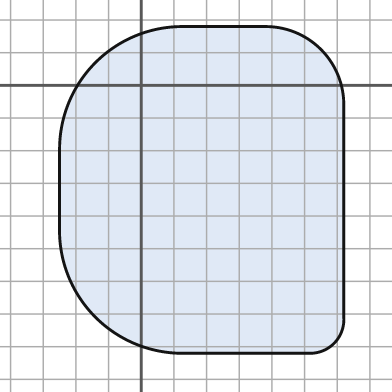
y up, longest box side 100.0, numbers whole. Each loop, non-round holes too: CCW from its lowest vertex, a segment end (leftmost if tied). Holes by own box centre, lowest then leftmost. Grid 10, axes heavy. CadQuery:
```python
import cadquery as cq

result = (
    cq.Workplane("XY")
    .moveTo(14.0, -82.0)
    .lineTo(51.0, -82.0)
    .threePointArc((59.0, -79.0), (62.0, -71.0))
    .lineTo(62.0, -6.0)
    .threePointArc((55.0, 11.0), (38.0, 18.0))
    .lineTo(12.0, 18.0)
    .threePointArc((-14.0, 7.0), (-25.0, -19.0))
    .lineTo(-25.0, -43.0)
    .threePointArc((-14.0, -71.0), (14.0, -82.0))
    .close()
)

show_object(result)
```